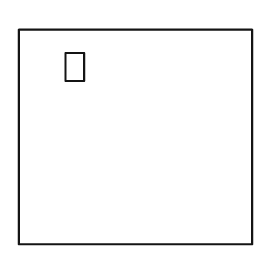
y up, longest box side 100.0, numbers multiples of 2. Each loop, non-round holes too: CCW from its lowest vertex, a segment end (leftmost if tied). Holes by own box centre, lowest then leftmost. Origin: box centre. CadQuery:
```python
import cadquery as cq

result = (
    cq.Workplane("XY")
    .moveTo(-50.0, -46.0)
    .lineTo(50.0, -46.0)
    .lineTo(50.0, 46.0)
    .lineTo(-50.0, 46.0)
    .close()
    .moveTo(-30.0, 24.0)
    .lineTo(-22.0, 24.0)
    .lineTo(-22.0, 36.0)
    .lineTo(-30.0, 36.0)
    .close()
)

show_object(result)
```